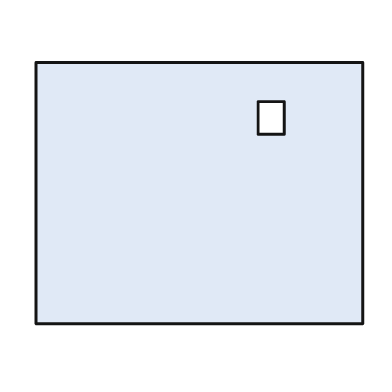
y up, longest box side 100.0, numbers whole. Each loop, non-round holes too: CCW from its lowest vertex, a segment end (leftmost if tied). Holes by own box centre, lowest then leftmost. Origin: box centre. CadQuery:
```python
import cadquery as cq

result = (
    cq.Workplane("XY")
    .moveTo(-50.0, -40.0)
    .lineTo(50.0, -40.0)
    .lineTo(50.0, 40.0)
    .lineTo(-50.0, 40.0)
    .close()
    .moveTo(18.0, 18.0)
    .lineTo(26.0, 18.0)
    .lineTo(26.0, 28.0)
    .lineTo(18.0, 28.0)
    .close()
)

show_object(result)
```